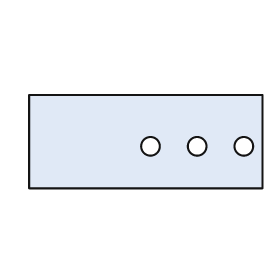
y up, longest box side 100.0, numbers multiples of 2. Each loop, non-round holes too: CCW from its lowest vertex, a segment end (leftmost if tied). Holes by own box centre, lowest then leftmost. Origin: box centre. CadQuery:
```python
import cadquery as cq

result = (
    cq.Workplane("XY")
    .moveTo(-50.0, -20.0)
    .lineTo(50.0, -20.0)
    .lineTo(50.0, 20.0)
    .lineTo(-50.0, 20.0)
    .close()
    .moveTo(2.0, -2.0)
    .circle(4.0)
    .moveTo(22.0, -2.0)
    .circle(4.0)
    .moveTo(42.0, -2.0)
    .circle(4.0)
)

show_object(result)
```